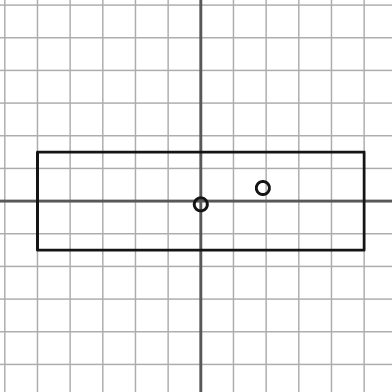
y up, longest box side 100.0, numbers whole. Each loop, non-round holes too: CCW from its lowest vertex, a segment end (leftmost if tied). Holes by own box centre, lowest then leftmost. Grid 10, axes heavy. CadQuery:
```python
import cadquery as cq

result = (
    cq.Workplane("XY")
    .moveTo(-50.0, -15.0)
    .lineTo(50.0, -15.0)
    .lineTo(50.0, 15.0)
    .lineTo(-50.0, 15.0)
    .close()
    .moveTo(0.0, -1.0)
    .circle(2.0)
    .moveTo(19.0, 4.0)
    .circle(2.0)
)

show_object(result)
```